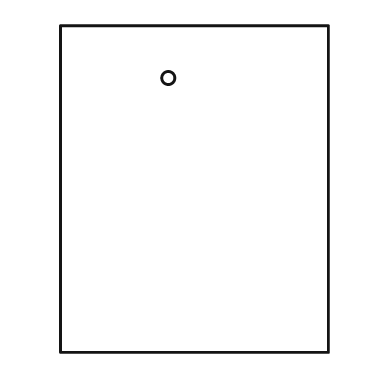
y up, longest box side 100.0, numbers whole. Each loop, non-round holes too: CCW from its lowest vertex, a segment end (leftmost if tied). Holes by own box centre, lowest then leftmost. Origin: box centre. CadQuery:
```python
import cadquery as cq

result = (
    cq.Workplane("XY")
    .moveTo(-41.0, -50.0)
    .lineTo(41.0, -50.0)
    .lineTo(41.0, 50.0)
    .lineTo(-41.0, 50.0)
    .close()
    .moveTo(-8.0, 34.0)
    .circle(2.0)
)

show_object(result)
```